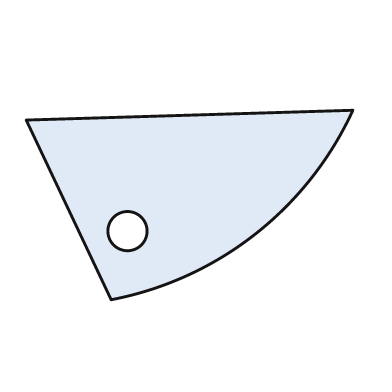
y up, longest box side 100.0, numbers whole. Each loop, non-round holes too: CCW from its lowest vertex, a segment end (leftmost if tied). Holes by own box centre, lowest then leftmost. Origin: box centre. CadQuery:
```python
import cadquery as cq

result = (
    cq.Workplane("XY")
    .moveTo(-24.0, -29.0)
    .threePointArc((20.0, -9.0), (50.0, 29.0))
    .lineTo(-50.0, 26.0)
    .close()
    .moveTo(-19.0, -8.0)
    .circle(6.0)
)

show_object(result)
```